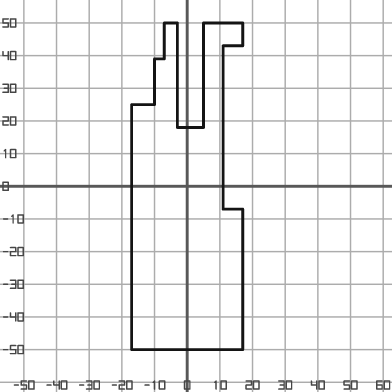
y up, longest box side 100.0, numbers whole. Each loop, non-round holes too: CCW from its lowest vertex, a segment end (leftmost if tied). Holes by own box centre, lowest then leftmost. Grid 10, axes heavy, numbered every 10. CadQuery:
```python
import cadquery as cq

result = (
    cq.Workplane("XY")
    .moveTo(-17.0, -50.0)
    .lineTo(17.0, -50.0)
    .lineTo(17.0, -7.0)
    .lineTo(11.0, -7.0)
    .lineTo(11.0, 43.0)
    .lineTo(17.0, 43.0)
    .lineTo(17.0, 50.0)
    .lineTo(5.0, 50.0)
    .lineTo(5.0, 18.0)
    .lineTo(-3.0, 18.0)
    .lineTo(-3.0, 50.0)
    .lineTo(-7.0, 50.0)
    .lineTo(-7.0, 39.0)
    .lineTo(-10.0, 39.0)
    .lineTo(-10.0, 25.0)
    .lineTo(-17.0, 25.0)
    .close()
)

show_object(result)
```